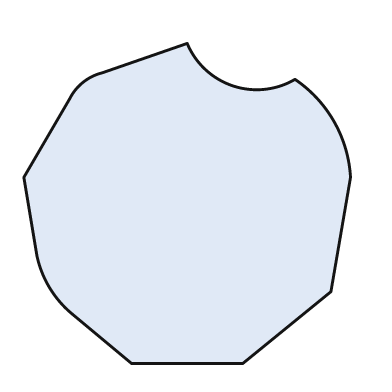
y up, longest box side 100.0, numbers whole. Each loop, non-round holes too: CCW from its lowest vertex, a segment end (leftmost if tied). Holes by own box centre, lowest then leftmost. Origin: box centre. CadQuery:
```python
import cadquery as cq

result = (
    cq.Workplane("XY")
    .moveTo(-17.0, -49.0)
    .lineTo(17.0, -49.0)
    .lineTo(44.0, -27.0)
    .lineTo(50.0, 8.0)
    .threePointArc((45.0, 25.0), (33.0, 38.0))
    .threePointArc((14.0, 36.0), (0.0, 49.0))
    .lineTo(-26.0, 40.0)
    .threePointArc((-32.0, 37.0), (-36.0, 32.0))
    .lineTo(-50.0, 8.0)
    .lineTo(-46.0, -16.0)
    .threePointArc((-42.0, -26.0), (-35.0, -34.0))
    .close()
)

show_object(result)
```